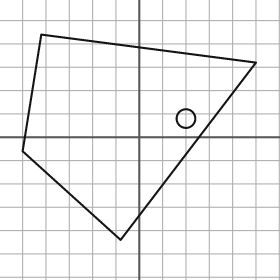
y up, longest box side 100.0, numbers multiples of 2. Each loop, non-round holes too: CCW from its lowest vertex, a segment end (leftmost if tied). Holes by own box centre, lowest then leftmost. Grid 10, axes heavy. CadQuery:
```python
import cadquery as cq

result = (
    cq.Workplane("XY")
    .moveTo(-8.0, -44.0)
    .lineTo(50.0, 32.0)
    .lineTo(-42.0, 44.0)
    .lineTo(-50.0, -6.0)
    .close()
    .moveTo(20.0, 8.0)
    .circle(4.0)
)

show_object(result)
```